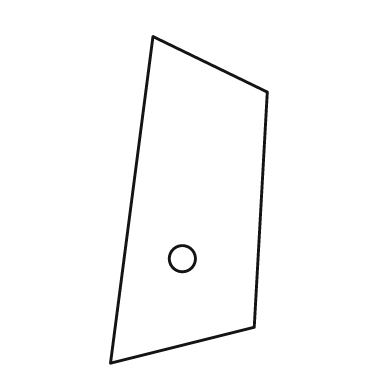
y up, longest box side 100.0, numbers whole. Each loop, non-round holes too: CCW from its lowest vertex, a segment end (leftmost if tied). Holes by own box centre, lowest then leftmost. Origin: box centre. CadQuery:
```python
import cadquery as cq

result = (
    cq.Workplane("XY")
    .moveTo(-24.0, -50.0)
    .lineTo(20.0, -39.0)
    .lineTo(24.0, 33.0)
    .lineTo(-11.0, 50.0)
    .close()
    .moveTo(-2.0, -18.0)
    .circle(4.0)
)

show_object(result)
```